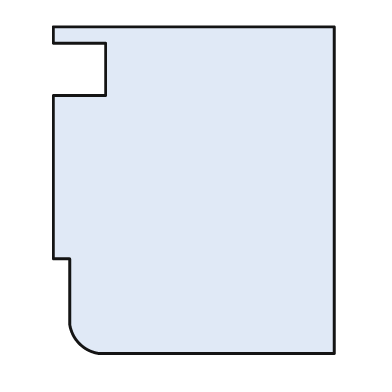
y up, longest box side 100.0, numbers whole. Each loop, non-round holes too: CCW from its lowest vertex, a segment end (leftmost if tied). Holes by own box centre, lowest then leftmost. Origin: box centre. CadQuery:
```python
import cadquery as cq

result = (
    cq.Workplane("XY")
    .moveTo(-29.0, -50.0)
    .lineTo(43.0, -50.0)
    .lineTo(43.0, 50.0)
    .lineTo(-43.0, 50.0)
    .lineTo(-43.0, 45.0)
    .lineTo(-27.0, 45.0)
    .lineTo(-27.0, 29.0)
    .lineTo(-43.0, 29.0)
    .lineTo(-43.0, -21.0)
    .lineTo(-38.0, -21.0)
    .lineTo(-38.0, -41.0)
    .threePointArc((-35.0, -47.0), (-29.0, -50.0))
    .close()
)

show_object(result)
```